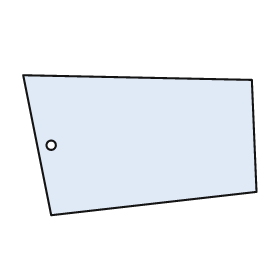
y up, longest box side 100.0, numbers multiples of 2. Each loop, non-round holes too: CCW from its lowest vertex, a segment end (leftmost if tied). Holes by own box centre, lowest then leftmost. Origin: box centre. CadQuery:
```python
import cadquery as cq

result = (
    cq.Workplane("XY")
    .moveTo(-38.0, -30.0)
    .lineTo(50.0, -20.0)
    .lineTo(48.0, 28.0)
    .lineTo(-50.0, 30.0)
    .close()
    .moveTo(-38.0, 0.0)
    .circle(2.0)
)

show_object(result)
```